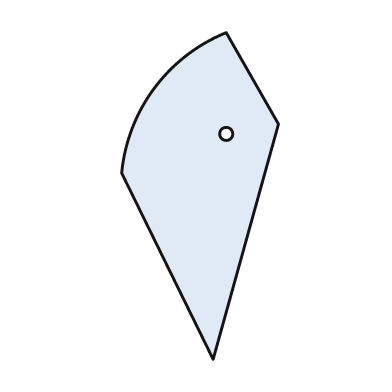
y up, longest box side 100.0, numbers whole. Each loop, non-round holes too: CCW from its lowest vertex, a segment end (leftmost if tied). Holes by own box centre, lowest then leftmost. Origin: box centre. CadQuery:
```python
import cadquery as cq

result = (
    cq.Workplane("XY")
    .moveTo(4.0, -50.0)
    .lineTo(24.0, 22.0)
    .lineTo(8.0, 50.0)
    .threePointArc((-14.0, 33.0), (-24.0, 7.0))
    .close()
    .moveTo(8.0, 19.0)
    .circle(2.0)
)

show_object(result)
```